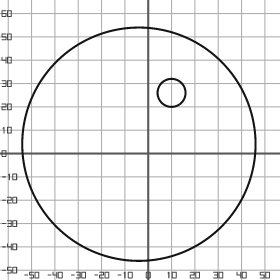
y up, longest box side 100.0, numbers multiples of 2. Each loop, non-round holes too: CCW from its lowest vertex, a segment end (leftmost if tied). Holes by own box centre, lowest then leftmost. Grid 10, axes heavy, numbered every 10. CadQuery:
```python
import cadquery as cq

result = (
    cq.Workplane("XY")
    .moveTo(-4.0, 4.0)
    .circle(50.0)
    .moveTo(10.0, 26.0)
    .circle(6.0)
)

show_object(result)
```